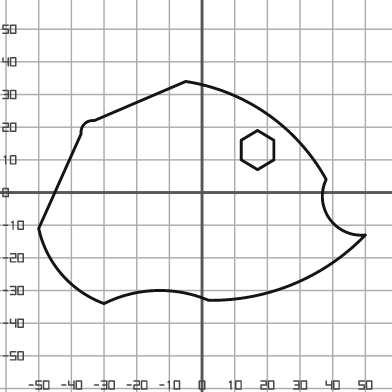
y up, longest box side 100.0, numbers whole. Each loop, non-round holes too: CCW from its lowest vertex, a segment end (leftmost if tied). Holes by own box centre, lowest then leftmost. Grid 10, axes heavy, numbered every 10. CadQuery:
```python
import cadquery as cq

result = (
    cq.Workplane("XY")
    .moveTo(-30.0, -34.0)
    .threePointArc((-14.0, -30.0), (2.0, -33.0))
    .threePointArc((28.0, -28.0), (50.0, -13.0))
    .threePointArc((39.0, -8.0), (38.0, 4.0))
    .threePointArc((20.0, 24.0), (-5.0, 34.0))
    .lineTo(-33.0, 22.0)
    .threePointArc((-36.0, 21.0), (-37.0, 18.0))
    .lineTo(-50.0, -11.0)
    .threePointArc((-43.0, -25.0), (-30.0, -34.0))
    .close()
    .moveTo(17.0, 7.0)
    .lineTo(22.0, 10.0)
    .lineTo(22.0, 16.0)
    .lineTo(17.0, 19.0)
    .lineTo(12.0, 16.0)
    .lineTo(12.0, 10.0)
    .close()
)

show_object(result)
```